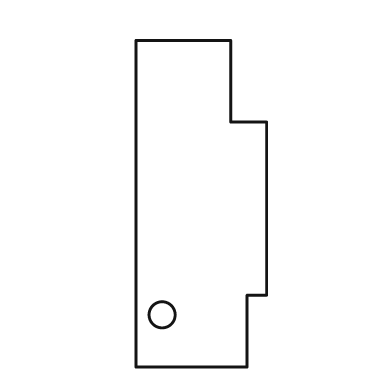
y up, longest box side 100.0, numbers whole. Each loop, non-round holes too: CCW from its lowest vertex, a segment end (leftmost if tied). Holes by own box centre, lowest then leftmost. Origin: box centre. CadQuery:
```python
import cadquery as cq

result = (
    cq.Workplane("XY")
    .moveTo(-20.0, -50.0)
    .lineTo(14.0, -50.0)
    .lineTo(14.0, -28.0)
    .lineTo(20.0, -28.0)
    .lineTo(20.0, 25.0)
    .lineTo(9.0, 25.0)
    .lineTo(9.0, 50.0)
    .lineTo(-20.0, 50.0)
    .close()
    .moveTo(-12.0, -34.0)
    .circle(4.0)
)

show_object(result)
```